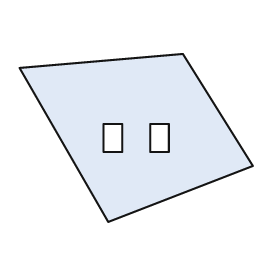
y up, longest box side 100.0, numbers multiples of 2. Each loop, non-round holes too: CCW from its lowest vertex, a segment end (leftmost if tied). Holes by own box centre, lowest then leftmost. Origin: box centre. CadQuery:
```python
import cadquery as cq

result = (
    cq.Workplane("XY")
    .moveTo(-12.0, -36.0)
    .lineTo(50.0, -12.0)
    .lineTo(20.0, 36.0)
    .lineTo(-50.0, 30.0)
    .close()
    .moveTo(-14.0, -6.0)
    .lineTo(-6.0, -6.0)
    .lineTo(-6.0, 6.0)
    .lineTo(-14.0, 6.0)
    .close()
    .moveTo(6.0, -6.0)
    .lineTo(14.0, -6.0)
    .lineTo(14.0, 6.0)
    .lineTo(6.0, 6.0)
    .close()
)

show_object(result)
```